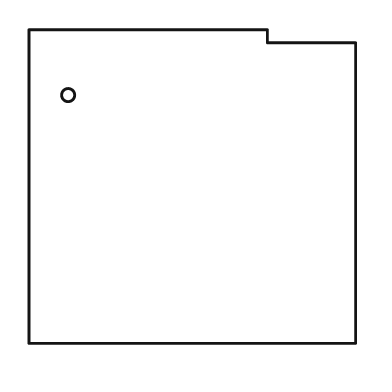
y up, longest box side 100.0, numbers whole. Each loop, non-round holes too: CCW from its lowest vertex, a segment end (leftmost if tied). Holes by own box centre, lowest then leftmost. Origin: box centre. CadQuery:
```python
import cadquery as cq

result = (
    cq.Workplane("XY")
    .moveTo(-50.0, -48.0)
    .lineTo(50.0, -48.0)
    .lineTo(50.0, 44.0)
    .lineTo(23.0, 44.0)
    .lineTo(23.0, 48.0)
    .lineTo(-50.0, 48.0)
    .close()
    .moveTo(-38.0, 28.0)
    .circle(2.0)
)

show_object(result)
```